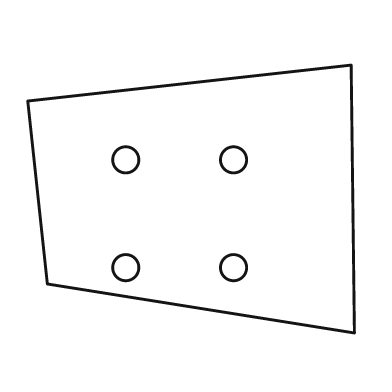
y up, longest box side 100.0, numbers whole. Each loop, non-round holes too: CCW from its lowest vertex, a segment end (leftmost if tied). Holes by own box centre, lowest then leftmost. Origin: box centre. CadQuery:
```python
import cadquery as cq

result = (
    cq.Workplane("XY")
    .moveTo(50.0, -41.0)
    .lineTo(49.0, 41.0)
    .lineTo(-50.0, 30.0)
    .lineTo(-44.0, -26.0)
    .close()
    .moveTo(-20.0, -21.0)
    .circle(4.0)
    .moveTo(13.0, -21.0)
    .circle(4.0)
    .moveTo(-20.0, 12.0)
    .circle(4.0)
    .moveTo(13.0, 12.0)
    .circle(4.0)
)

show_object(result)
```